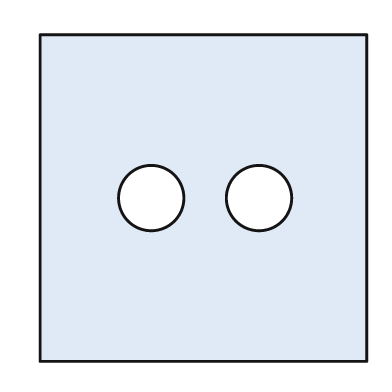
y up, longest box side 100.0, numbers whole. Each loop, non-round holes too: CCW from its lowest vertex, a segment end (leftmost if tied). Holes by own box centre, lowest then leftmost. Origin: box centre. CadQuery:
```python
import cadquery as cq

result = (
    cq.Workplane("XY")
    .moveTo(-50.0, -50.0)
    .lineTo(50.0, -50.0)
    .lineTo(50.0, 50.0)
    .lineTo(-50.0, 50.0)
    .close()
    .moveTo(-16.0, 0.0)
    .circle(10.0)
    .moveTo(17.0, 0.0)
    .circle(10.0)
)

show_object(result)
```